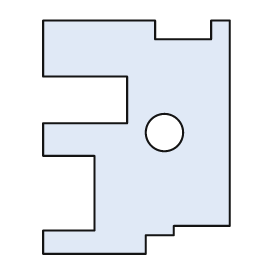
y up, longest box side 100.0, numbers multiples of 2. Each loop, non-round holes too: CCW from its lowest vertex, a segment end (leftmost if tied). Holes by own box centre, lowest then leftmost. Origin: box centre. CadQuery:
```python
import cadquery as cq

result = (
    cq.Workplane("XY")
    .moveTo(-40.0, -50.0)
    .lineTo(4.0, -50.0)
    .lineTo(4.0, -42.0)
    .lineTo(16.0, -42.0)
    .lineTo(16.0, -38.0)
    .lineTo(40.0, -38.0)
    .lineTo(40.0, 50.0)
    .lineTo(32.0, 50.0)
    .lineTo(32.0, 42.0)
    .lineTo(8.0, 42.0)
    .lineTo(8.0, 50.0)
    .lineTo(-40.0, 50.0)
    .lineTo(-40.0, 26.0)
    .lineTo(-4.0, 26.0)
    .lineTo(-4.0, 6.0)
    .lineTo(-40.0, 6.0)
    .lineTo(-40.0, -8.0)
    .lineTo(-18.0, -8.0)
    .lineTo(-18.0, -40.0)
    .lineTo(-40.0, -40.0)
    .close()
    .moveTo(12.0, 2.0)
    .circle(8.0)
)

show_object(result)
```